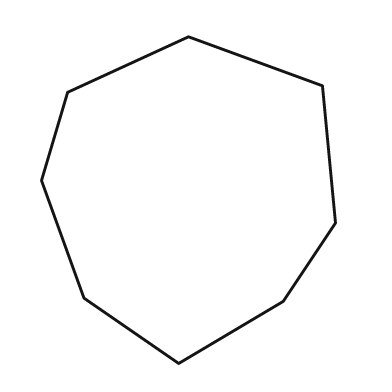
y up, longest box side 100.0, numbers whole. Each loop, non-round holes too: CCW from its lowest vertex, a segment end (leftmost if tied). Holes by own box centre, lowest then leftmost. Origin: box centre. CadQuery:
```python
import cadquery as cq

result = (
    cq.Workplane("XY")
    .moveTo(-3.0, -50.0)
    .lineTo(29.0, -31.0)
    .lineTo(45.0, -7.0)
    .lineTo(41.0, 35.0)
    .lineTo(0.0, 50.0)
    .lineTo(-37.0, 33.0)
    .lineTo(-45.0, 6.0)
    .lineTo(-32.0, -30.0)
    .close()
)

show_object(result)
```